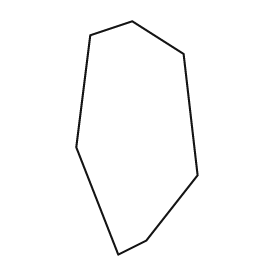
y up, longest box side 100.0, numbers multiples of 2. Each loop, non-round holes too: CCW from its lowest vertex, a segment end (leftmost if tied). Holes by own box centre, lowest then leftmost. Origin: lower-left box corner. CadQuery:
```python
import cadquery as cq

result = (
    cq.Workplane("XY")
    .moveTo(18.0, 0.0)
    .lineTo(30.0, 6.0)
    .lineTo(52.0, 34.0)
    .lineTo(46.0, 86.0)
    .lineTo(24.0, 100.0)
    .lineTo(6.0, 94.0)
    .lineTo(0.0, 46.0)
    .close()
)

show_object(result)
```